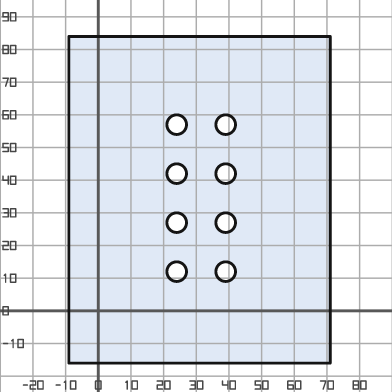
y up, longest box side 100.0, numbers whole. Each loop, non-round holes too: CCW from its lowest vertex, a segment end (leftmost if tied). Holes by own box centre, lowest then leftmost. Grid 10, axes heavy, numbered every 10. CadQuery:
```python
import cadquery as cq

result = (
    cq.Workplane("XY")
    .moveTo(-9.0, -16.0)
    .lineTo(71.0, -16.0)
    .lineTo(71.0, 84.0)
    .lineTo(-9.0, 84.0)
    .close()
    .moveTo(24.0, 12.0)
    .circle(3.0)
    .moveTo(39.0, 12.0)
    .circle(3.0)
    .moveTo(24.0, 27.0)
    .circle(3.0)
    .moveTo(39.0, 27.0)
    .circle(3.0)
    .moveTo(24.0, 42.0)
    .circle(3.0)
    .moveTo(39.0, 42.0)
    .circle(3.0)
    .moveTo(24.0, 57.0)
    .circle(3.0)
    .moveTo(39.0, 57.0)
    .circle(3.0)
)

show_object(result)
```